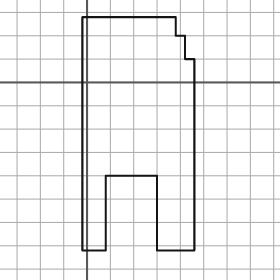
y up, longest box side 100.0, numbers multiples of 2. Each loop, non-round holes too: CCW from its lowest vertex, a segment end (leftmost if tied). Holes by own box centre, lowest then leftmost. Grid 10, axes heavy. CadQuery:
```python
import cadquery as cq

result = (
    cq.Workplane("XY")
    .moveTo(-2.0, -72.0)
    .lineTo(8.0, -72.0)
    .lineTo(8.0, -40.0)
    .lineTo(30.0, -40.0)
    .lineTo(30.0, -72.0)
    .lineTo(46.0, -72.0)
    .lineTo(46.0, 10.0)
    .lineTo(42.0, 10.0)
    .lineTo(42.0, 20.0)
    .lineTo(38.0, 20.0)
    .lineTo(38.0, 28.0)
    .lineTo(-2.0, 28.0)
    .close()
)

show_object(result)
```